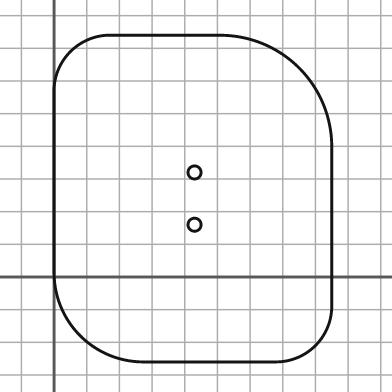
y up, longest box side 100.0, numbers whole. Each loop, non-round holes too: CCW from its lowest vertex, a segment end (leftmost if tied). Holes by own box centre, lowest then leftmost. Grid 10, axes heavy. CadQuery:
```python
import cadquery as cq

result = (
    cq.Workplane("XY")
    .moveTo(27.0, -26.0)
    .lineTo(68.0, -26.0)
    .threePointArc((80.0, -21.0), (85.0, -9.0))
    .lineTo(85.0, 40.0)
    .threePointArc((75.0, 64.0), (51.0, 74.0))
    .lineTo(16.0, 74.0)
    .threePointArc((5.0, 69.0), (0.0, 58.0))
    .lineTo(0.0, 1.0)
    .threePointArc((8.0, -18.0), (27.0, -26.0))
    .close()
    .moveTo(43.0, 16.0)
    .circle(2.0)
    .moveTo(43.0, 32.0)
    .circle(2.0)
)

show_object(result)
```